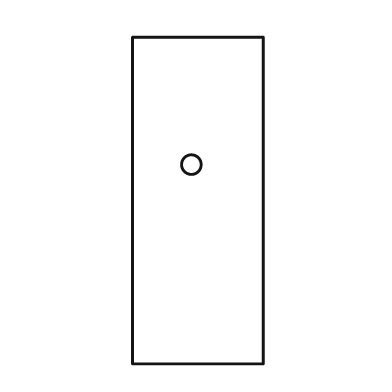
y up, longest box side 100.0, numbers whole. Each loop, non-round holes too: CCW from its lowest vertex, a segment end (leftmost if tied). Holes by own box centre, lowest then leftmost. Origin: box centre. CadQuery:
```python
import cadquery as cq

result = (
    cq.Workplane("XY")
    .moveTo(-20.0, -50.0)
    .lineTo(20.0, -50.0)
    .lineTo(20.0, 50.0)
    .lineTo(-20.0, 50.0)
    .close()
    .moveTo(-2.0, 11.0)
    .circle(3.0)
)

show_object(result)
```